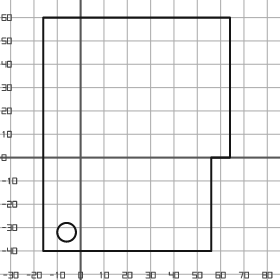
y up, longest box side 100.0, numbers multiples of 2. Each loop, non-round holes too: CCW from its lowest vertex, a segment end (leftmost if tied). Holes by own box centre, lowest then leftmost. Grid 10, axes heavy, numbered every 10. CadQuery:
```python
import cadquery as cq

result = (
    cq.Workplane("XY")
    .moveTo(-16.0, -40.0)
    .lineTo(56.0, -40.0)
    .lineTo(56.0, 0.0)
    .lineTo(64.0, 0.0)
    .lineTo(64.0, 60.0)
    .lineTo(-16.0, 60.0)
    .close()
    .moveTo(-6.0, -32.0)
    .circle(4.0)
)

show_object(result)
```